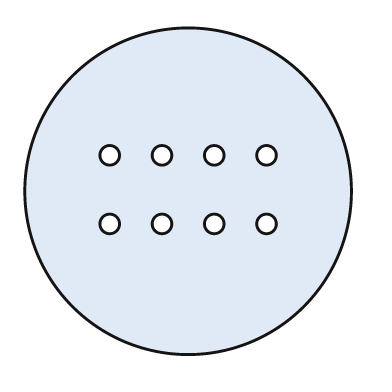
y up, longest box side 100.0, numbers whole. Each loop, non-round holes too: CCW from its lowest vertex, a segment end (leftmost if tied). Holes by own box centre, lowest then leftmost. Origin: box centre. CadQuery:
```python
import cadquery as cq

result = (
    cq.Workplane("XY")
    .moveTo(0.0, 0.0)
    .circle(50.0)
    .moveTo(-24.0, -10.0)
    .circle(3.0)
    .moveTo(-8.0, -10.0)
    .circle(3.0)
    .moveTo(8.0, -10.0)
    .circle(3.0)
    .moveTo(24.0, -10.0)
    .circle(3.0)
    .moveTo(-24.0, 11.0)
    .circle(3.0)
    .moveTo(-8.0, 11.0)
    .circle(3.0)
    .moveTo(8.0, 11.0)
    .circle(3.0)
    .moveTo(24.0, 11.0)
    .circle(3.0)
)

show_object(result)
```